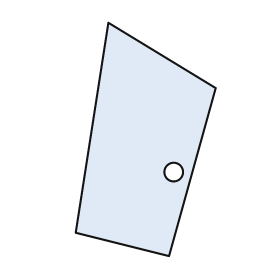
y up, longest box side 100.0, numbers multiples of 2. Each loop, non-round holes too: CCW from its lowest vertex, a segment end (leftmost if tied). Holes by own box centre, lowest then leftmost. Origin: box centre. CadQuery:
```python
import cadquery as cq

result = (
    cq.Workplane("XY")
    .moveTo(10.0, -50.0)
    .lineTo(30.0, 22.0)
    .lineTo(-16.0, 50.0)
    .lineTo(-30.0, -40.0)
    .close()
    .moveTo(12.0, -14.0)
    .circle(4.0)
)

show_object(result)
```